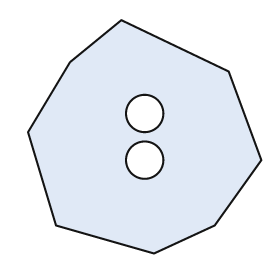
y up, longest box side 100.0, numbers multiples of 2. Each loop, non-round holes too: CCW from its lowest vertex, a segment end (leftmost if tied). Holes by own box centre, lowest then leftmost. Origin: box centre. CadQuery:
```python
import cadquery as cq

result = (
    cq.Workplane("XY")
    .moveTo(4.0, -50.0)
    .lineTo(30.0, -38.0)
    .lineTo(50.0, -10.0)
    .lineTo(36.0, 28.0)
    .lineTo(-10.0, 50.0)
    .lineTo(-32.0, 32.0)
    .lineTo(-50.0, 2.0)
    .lineTo(-38.0, -38.0)
    .close()
    .moveTo(0.0, -10.0)
    .circle(8.0)
    .moveTo(0.0, 10.0)
    .circle(8.0)
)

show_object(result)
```